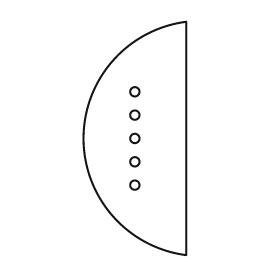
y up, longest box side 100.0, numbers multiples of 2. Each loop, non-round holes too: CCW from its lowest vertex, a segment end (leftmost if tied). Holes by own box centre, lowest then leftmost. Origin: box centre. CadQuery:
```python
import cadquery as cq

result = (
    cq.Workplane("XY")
    .moveTo(22.0, -50.0)
    .lineTo(22.0, 50.0)
    .threePointArc((-22.0, 0.0), (22.0, -50.0))
    .close()
    .moveTo(0.0, -20.0)
    .circle(2.0)
    .moveTo(0.0, -10.0)
    .circle(2.0)
    .moveTo(0.0, 0.0)
    .circle(2.0)
    .moveTo(0.0, 10.0)
    .circle(2.0)
    .moveTo(0.0, 20.0)
    .circle(2.0)
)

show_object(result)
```